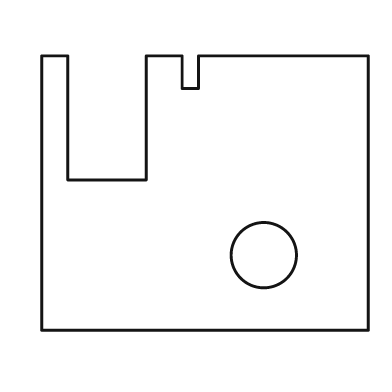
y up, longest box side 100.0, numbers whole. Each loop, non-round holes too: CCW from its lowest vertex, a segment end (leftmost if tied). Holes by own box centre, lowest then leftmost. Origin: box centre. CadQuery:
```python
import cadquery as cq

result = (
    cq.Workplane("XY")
    .moveTo(-50.0, -42.0)
    .lineTo(50.0, -42.0)
    .lineTo(50.0, 42.0)
    .lineTo(-2.0, 42.0)
    .lineTo(-2.0, 32.0)
    .lineTo(-7.0, 32.0)
    .lineTo(-7.0, 42.0)
    .lineTo(-18.0, 42.0)
    .lineTo(-18.0, 4.0)
    .lineTo(-42.0, 4.0)
    .lineTo(-42.0, 42.0)
    .lineTo(-50.0, 42.0)
    .close()
    .moveTo(18.0, -19.0)
    .circle(10.0)
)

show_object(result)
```